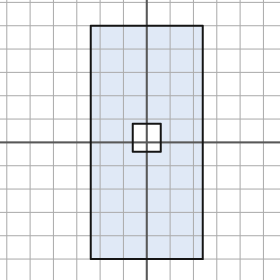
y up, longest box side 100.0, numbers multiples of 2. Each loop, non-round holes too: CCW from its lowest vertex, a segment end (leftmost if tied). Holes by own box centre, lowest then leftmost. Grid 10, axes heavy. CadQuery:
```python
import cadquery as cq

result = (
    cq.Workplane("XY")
    .moveTo(-24.0, -50.0)
    .lineTo(24.0, -50.0)
    .lineTo(24.0, 50.0)
    .lineTo(-24.0, 50.0)
    .close()
    .moveTo(-6.0, -4.0)
    .lineTo(6.0, -4.0)
    .lineTo(6.0, 8.0)
    .lineTo(-6.0, 8.0)
    .close()
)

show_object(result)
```